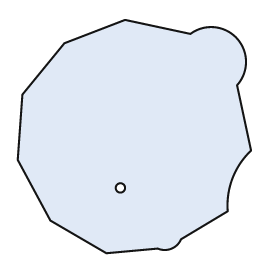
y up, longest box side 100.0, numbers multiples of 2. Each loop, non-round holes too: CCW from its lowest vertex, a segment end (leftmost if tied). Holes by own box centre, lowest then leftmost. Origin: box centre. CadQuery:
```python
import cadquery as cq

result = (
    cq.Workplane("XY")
    .moveTo(-12.0, -50.0)
    .lineTo(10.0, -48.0)
    .threePointArc((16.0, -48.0), (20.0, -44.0))
    .lineTo(40.0, -32.0)
    .threePointArc((42.0, -18.0), (50.0, -6.0))
    .lineTo(44.0, 22.0)
    .threePointArc((44.0, 42.0), (24.0, 44.0))
    .lineTo(-4.0, 50.0)
    .lineTo(-30.0, 40.0)
    .lineTo(-48.0, 18.0)
    .lineTo(-50.0, -10.0)
    .lineTo(-36.0, -36.0)
    .close()
    .moveTo(-6.0, -22.0)
    .circle(2.0)
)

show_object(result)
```